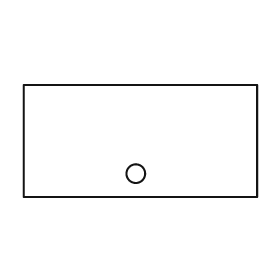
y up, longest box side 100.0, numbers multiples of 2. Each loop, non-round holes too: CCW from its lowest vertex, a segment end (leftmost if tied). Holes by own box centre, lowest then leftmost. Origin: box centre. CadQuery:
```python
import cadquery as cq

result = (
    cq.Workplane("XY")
    .moveTo(-50.0, -24.0)
    .lineTo(50.0, -24.0)
    .lineTo(50.0, 24.0)
    .lineTo(-50.0, 24.0)
    .close()
    .moveTo(-2.0, -14.0)
    .circle(4.0)
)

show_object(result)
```